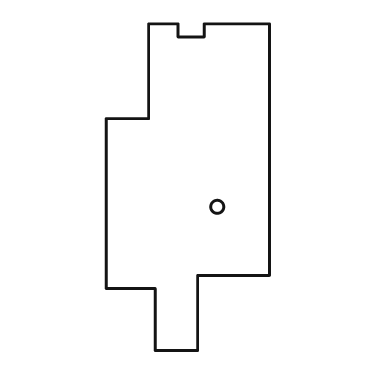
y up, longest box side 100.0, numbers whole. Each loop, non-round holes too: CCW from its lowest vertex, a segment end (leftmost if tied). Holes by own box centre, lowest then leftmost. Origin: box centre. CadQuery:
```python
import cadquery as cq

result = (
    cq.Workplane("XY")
    .moveTo(-10.0, -50.0)
    .lineTo(3.0, -50.0)
    .lineTo(3.0, -27.0)
    .lineTo(25.0, -27.0)
    .lineTo(25.0, 50.0)
    .lineTo(5.0, 50.0)
    .lineTo(5.0, 46.0)
    .lineTo(-3.0, 46.0)
    .lineTo(-3.0, 50.0)
    .lineTo(-12.0, 50.0)
    .lineTo(-12.0, 21.0)
    .lineTo(-25.0, 21.0)
    .lineTo(-25.0, -31.0)
    .lineTo(-10.0, -31.0)
    .close()
    .moveTo(9.0, -6.0)
    .circle(2.0)
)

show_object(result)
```